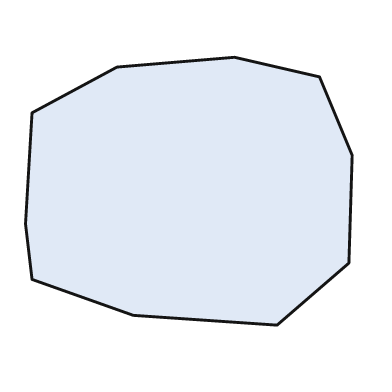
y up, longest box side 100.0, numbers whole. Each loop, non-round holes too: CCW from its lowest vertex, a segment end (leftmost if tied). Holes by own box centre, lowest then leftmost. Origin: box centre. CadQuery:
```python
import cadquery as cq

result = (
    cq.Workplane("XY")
    .moveTo(27.0, -41.0)
    .lineTo(49.0, -22.0)
    .lineTo(50.0, 11.0)
    .lineTo(40.0, 35.0)
    .lineTo(14.0, 41.0)
    .lineTo(-22.0, 38.0)
    .lineTo(-48.0, 24.0)
    .lineTo(-50.0, -10.0)
    .lineTo(-48.0, -27.0)
    .lineTo(-17.0, -38.0)
    .close()
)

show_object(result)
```